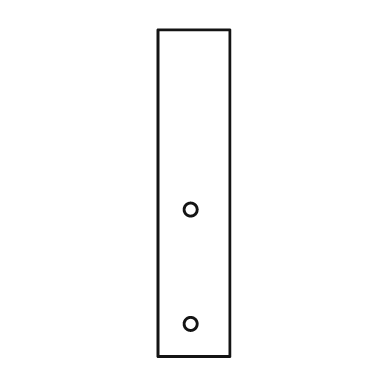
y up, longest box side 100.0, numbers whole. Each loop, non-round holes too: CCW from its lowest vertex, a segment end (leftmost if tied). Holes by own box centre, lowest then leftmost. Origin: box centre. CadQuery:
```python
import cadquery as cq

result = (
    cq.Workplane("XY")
    .moveTo(-11.0, -50.0)
    .lineTo(11.0, -50.0)
    .lineTo(11.0, 50.0)
    .lineTo(-11.0, 50.0)
    .close()
    .moveTo(-1.0, -40.0)
    .circle(2.0)
    .moveTo(-1.0, -5.0)
    .circle(2.0)
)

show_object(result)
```